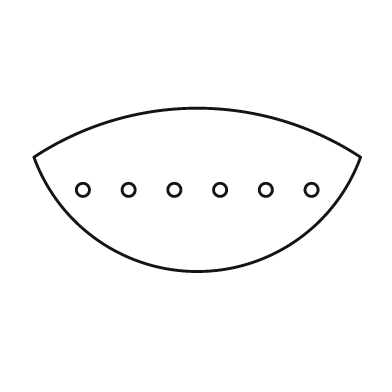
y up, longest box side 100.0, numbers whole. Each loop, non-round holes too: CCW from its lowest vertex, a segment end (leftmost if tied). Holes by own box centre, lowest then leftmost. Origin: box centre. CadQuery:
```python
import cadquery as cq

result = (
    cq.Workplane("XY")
    .moveTo(-50.0, 10.0)
    .threePointArc((0.0, -25.0), (50.0, 10.0))
    .threePointArc((0.0, 25.0), (-50.0, 10.0))
    .close()
    .moveTo(-35.0, 0.0)
    .circle(2.0)
    .moveTo(-21.0, 0.0)
    .circle(2.0)
    .moveTo(-7.0, 0.0)
    .circle(2.0)
    .moveTo(7.0, 0.0)
    .circle(2.0)
    .moveTo(21.0, 0.0)
    .circle(2.0)
    .moveTo(35.0, 0.0)
    .circle(2.0)
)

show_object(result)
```